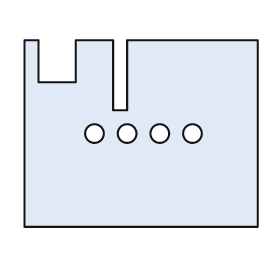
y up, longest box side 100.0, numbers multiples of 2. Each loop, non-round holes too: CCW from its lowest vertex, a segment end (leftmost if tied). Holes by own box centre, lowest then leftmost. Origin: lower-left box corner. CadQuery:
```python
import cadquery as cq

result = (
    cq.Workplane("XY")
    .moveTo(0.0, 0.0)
    .lineTo(100.0, 0.0)
    .lineTo(100.0, 80.0)
    .lineTo(44.0, 80.0)
    .lineTo(44.0, 50.0)
    .lineTo(38.0, 50.0)
    .lineTo(38.0, 80.0)
    .lineTo(22.0, 80.0)
    .lineTo(22.0, 62.0)
    .lineTo(6.0, 62.0)
    .lineTo(6.0, 80.0)
    .lineTo(0.0, 80.0)
    .close()
    .moveTo(30.0, 40.0)
    .circle(4.0)
    .moveTo(44.0, 40.0)
    .circle(4.0)
    .moveTo(58.0, 40.0)
    .circle(4.0)
    .moveTo(72.0, 40.0)
    .circle(4.0)
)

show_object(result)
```